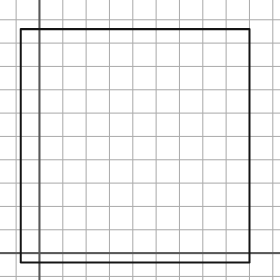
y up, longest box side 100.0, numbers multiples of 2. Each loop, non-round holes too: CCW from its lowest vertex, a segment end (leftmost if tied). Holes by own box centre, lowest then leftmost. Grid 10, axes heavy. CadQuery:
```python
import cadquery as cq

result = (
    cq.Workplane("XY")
    .moveTo(-8.0, -4.0)
    .lineTo(90.0, -4.0)
    .lineTo(90.0, 96.0)
    .lineTo(-8.0, 96.0)
    .close()
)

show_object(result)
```